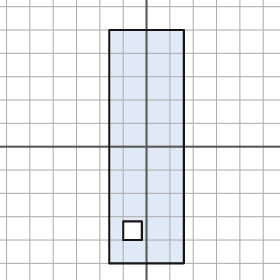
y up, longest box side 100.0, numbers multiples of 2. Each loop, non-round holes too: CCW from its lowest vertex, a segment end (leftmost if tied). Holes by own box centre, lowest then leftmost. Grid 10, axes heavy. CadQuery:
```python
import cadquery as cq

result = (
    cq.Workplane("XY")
    .moveTo(-16.0, -50.0)
    .lineTo(16.0, -50.0)
    .lineTo(16.0, 50.0)
    .lineTo(-16.0, 50.0)
    .close()
    .moveTo(-10.0, -40.0)
    .lineTo(-2.0, -40.0)
    .lineTo(-2.0, -32.0)
    .lineTo(-10.0, -32.0)
    .close()
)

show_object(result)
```